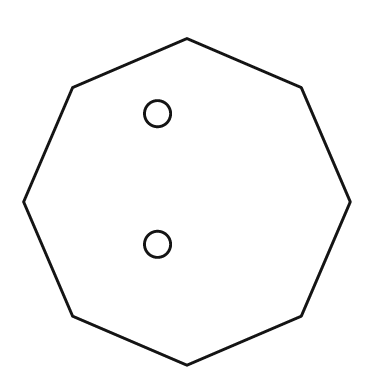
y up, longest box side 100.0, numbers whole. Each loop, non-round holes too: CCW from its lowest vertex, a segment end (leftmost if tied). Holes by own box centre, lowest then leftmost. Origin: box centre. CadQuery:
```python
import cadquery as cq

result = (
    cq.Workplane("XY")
    .moveTo(0.0, -50.0)
    .lineTo(35.0, -35.0)
    .lineTo(50.0, 0.0)
    .lineTo(35.0, 35.0)
    .lineTo(0.0, 50.0)
    .lineTo(-35.0, 35.0)
    .lineTo(-50.0, 0.0)
    .lineTo(-35.0, -35.0)
    .close()
    .moveTo(-9.0, -13.0)
    .circle(4.0)
    .moveTo(-9.0, 27.0)
    .circle(4.0)
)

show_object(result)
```